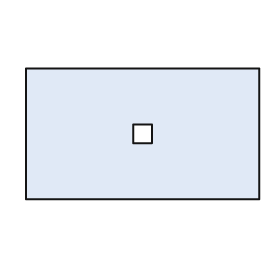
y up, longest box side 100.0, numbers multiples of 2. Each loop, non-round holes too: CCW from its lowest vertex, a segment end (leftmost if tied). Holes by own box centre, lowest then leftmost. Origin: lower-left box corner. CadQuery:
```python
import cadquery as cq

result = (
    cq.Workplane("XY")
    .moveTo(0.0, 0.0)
    .lineTo(100.0, 0.0)
    .lineTo(100.0, 56.0)
    .lineTo(0.0, 56.0)
    .close()
    .moveTo(46.0, 24.0)
    .lineTo(54.0, 24.0)
    .lineTo(54.0, 32.0)
    .lineTo(46.0, 32.0)
    .close()
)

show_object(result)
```